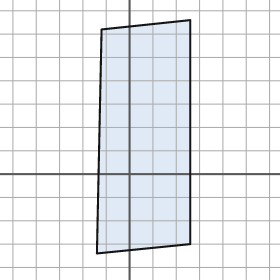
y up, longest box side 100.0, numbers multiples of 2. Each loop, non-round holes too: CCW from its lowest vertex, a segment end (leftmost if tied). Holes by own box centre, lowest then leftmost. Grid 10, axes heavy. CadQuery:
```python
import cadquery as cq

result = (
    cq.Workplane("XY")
    .moveTo(-14.0, -34.0)
    .lineTo(26.0, -30.0)
    .lineTo(26.0, 66.0)
    .lineTo(-12.0, 62.0)
    .close()
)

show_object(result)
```